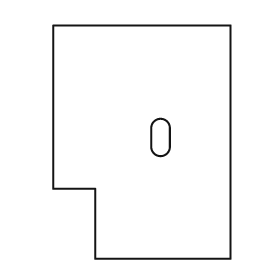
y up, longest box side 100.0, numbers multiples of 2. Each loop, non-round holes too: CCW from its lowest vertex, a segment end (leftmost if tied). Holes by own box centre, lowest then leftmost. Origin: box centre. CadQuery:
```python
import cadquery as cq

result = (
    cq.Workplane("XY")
    .moveTo(-20.0, -50.0)
    .lineTo(38.0, -50.0)
    .lineTo(38.0, 50.0)
    .lineTo(-38.0, 50.0)
    .lineTo(-38.0, -20.0)
    .lineTo(-20.0, -20.0)
    .close()
    .moveTo(4.0, -2.0)
    .threePointArc((8.0, -6.0), (12.0, -2.0))
    .lineTo(12.0, 6.0)
    .threePointArc((8.0, 10.0), (4.0, 6.0))
    .close()
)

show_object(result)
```